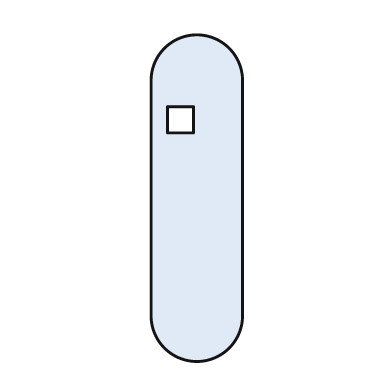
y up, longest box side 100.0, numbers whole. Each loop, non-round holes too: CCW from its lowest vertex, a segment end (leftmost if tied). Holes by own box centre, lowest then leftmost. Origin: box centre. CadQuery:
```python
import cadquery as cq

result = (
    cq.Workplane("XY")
    .moveTo(-14.0, -36.0)
    .threePointArc((0.0, -50.0), (14.0, -36.0))
    .lineTo(14.0, 36.0)
    .threePointArc((0.0, 50.0), (-14.0, 36.0))
    .close()
    .moveTo(-9.0, 20.0)
    .lineTo(-1.0, 20.0)
    .lineTo(-1.0, 28.0)
    .lineTo(-9.0, 28.0)
    .close()
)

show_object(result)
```